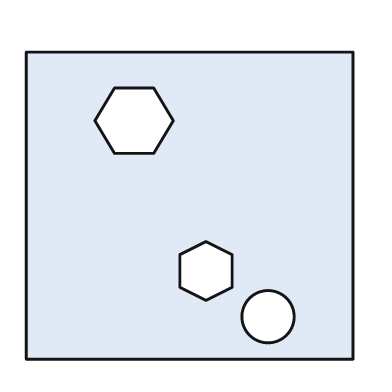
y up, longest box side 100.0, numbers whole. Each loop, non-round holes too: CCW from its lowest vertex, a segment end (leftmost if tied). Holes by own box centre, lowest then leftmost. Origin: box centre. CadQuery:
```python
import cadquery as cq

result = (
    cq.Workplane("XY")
    .moveTo(-50.0, -47.0)
    .lineTo(50.0, -47.0)
    .lineTo(50.0, 47.0)
    .lineTo(-50.0, 47.0)
    .close()
    .moveTo(24.0, -34.0)
    .circle(8.0)
    .moveTo(5.0, -29.0)
    .lineTo(13.0, -25.0)
    .lineTo(13.0, -15.0)
    .lineTo(5.0, -11.0)
    .lineTo(-3.0, -15.0)
    .lineTo(-3.0, -25.0)
    .close()
    .moveTo(-23.0, 16.0)
    .lineTo(-11.0, 16.0)
    .lineTo(-5.0, 26.0)
    .lineTo(-11.0, 36.0)
    .lineTo(-23.0, 36.0)
    .lineTo(-29.0, 26.0)
    .close()
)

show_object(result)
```